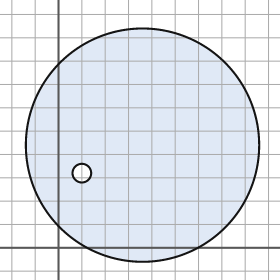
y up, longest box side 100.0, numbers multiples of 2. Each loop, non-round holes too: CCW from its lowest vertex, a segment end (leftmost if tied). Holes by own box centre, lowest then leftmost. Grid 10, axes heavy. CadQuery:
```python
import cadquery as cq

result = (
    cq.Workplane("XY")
    .moveTo(36.0, 44.0)
    .circle(50.0)
    .moveTo(10.0, 32.0)
    .circle(4.0)
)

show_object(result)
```